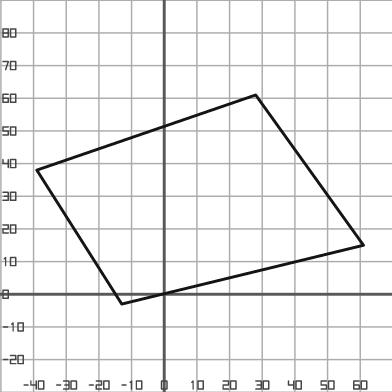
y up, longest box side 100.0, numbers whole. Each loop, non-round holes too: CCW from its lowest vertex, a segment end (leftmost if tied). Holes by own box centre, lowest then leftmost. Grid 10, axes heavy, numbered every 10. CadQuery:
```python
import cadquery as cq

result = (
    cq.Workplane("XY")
    .moveTo(-13.0, -3.0)
    .lineTo(61.0, 15.0)
    .lineTo(28.0, 61.0)
    .lineTo(-39.0, 38.0)
    .close()
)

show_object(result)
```